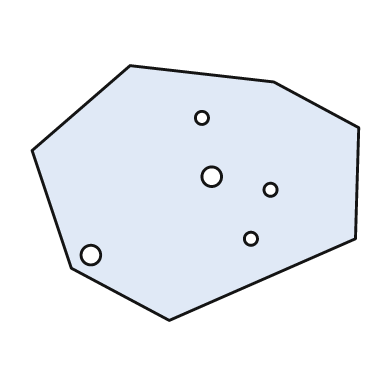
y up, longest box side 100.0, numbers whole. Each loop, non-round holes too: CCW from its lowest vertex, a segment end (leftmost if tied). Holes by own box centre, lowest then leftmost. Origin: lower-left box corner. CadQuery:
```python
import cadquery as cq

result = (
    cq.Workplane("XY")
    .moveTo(42.0, 0.0)
    .lineTo(99.0, 25.0)
    .lineTo(100.0, 59.0)
    .lineTo(74.0, 73.0)
    .lineTo(30.0, 78.0)
    .lineTo(0.0, 52.0)
    .lineTo(12.0, 16.0)
    .close()
    .moveTo(18.0, 20.0)
    .circle(3.0)
    .moveTo(67.0, 25.0)
    .circle(2.0)
    .moveTo(73.0, 40.0)
    .circle(2.0)
    .moveTo(55.0, 44.0)
    .circle(3.0)
    .moveTo(52.0, 62.0)
    .circle(2.0)
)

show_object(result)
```